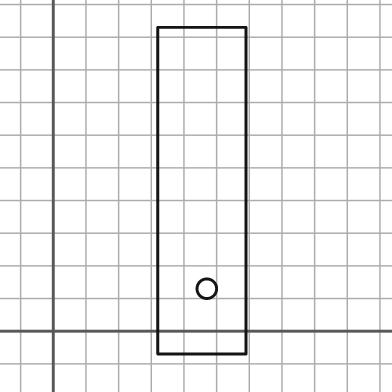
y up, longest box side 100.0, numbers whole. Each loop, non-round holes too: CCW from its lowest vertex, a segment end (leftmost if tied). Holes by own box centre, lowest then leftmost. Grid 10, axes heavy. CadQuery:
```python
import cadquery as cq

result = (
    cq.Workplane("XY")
    .moveTo(32.0, -7.0)
    .lineTo(59.0, -7.0)
    .lineTo(59.0, 93.0)
    .lineTo(32.0, 93.0)
    .close()
    .moveTo(47.0, 13.0)
    .circle(3.0)
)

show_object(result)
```